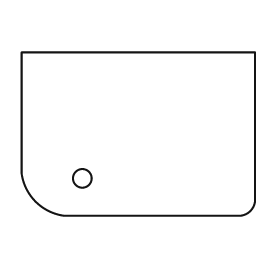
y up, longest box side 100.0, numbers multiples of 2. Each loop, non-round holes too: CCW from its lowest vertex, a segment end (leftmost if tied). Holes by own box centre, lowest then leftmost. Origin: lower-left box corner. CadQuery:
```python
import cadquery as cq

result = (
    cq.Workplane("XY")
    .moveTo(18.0, 0.0)
    .lineTo(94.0, 0.0)
    .threePointArc((98.0, 2.0), (100.0, 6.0))
    .lineTo(100.0, 70.0)
    .lineTo(0.0, 70.0)
    .lineTo(0.0, 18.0)
    .threePointArc((6.0, 6.0), (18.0, 0.0))
    .close()
    .moveTo(26.0, 16.0)
    .circle(4.0)
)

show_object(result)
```